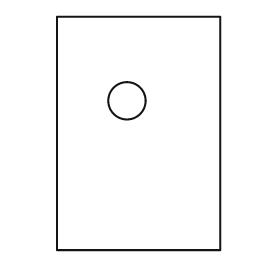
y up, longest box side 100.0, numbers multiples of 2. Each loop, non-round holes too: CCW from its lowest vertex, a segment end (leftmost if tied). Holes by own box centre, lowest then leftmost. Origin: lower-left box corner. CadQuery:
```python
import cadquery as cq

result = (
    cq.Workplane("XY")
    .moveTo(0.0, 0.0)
    .lineTo(70.0, 0.0)
    .lineTo(70.0, 100.0)
    .lineTo(0.0, 100.0)
    .close()
    .moveTo(30.0, 64.0)
    .circle(8.0)
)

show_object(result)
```